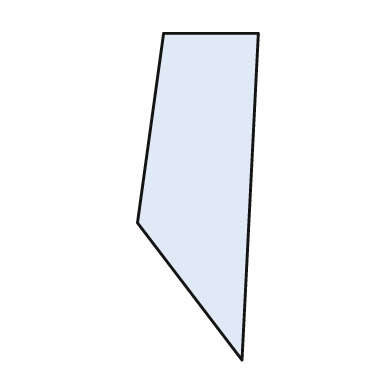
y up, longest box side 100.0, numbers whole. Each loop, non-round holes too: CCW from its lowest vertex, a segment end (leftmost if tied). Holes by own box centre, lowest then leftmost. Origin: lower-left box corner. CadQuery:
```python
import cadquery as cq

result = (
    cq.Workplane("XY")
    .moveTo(32.0, 0.0)
    .lineTo(37.0, 100.0)
    .lineTo(8.0, 100.0)
    .lineTo(0.0, 42.0)
    .close()
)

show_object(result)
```